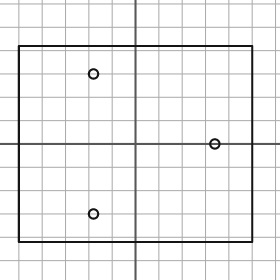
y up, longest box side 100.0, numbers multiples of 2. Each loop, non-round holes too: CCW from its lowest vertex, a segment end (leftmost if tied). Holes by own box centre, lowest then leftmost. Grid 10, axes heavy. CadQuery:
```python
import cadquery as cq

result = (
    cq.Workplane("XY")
    .moveTo(-50.0, -42.0)
    .lineTo(50.0, -42.0)
    .lineTo(50.0, 42.0)
    .lineTo(-50.0, 42.0)
    .close()
    .moveTo(-18.0, -30.0)
    .circle(2.0)
    .moveTo(34.0, 0.0)
    .circle(2.0)
    .moveTo(-18.0, 30.0)
    .circle(2.0)
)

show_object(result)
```